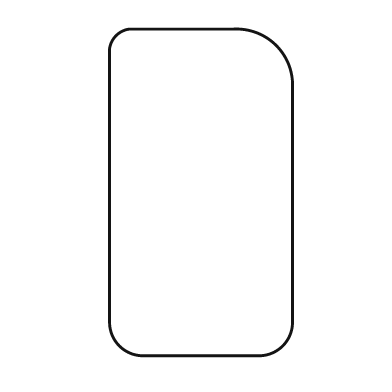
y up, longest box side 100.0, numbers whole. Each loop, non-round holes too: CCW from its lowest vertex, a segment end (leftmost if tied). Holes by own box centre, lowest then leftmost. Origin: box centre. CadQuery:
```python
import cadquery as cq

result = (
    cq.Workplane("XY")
    .moveTo(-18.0, -50.0)
    .lineTo(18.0, -50.0)
    .threePointArc((25.0, -47.0), (28.0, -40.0))
    .lineTo(28.0, 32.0)
    .threePointArc((23.0, 45.0), (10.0, 50.0))
    .lineTo(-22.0, 50.0)
    .threePointArc((-26.0, 48.0), (-28.0, 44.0))
    .lineTo(-28.0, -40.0)
    .threePointArc((-25.0, -47.0), (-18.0, -50.0))
    .close()
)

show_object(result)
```